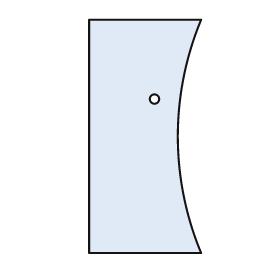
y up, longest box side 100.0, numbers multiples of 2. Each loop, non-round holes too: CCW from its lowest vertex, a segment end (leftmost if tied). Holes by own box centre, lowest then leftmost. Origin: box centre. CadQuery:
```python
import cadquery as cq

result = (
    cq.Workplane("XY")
    .moveTo(-24.0, -50.0)
    .lineTo(24.0, -50.0)
    .threePointArc((14.0, 0.0), (24.0, 50.0))
    .lineTo(-24.0, 50.0)
    .close()
    .moveTo(4.0, 16.0)
    .circle(2.0)
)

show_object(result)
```